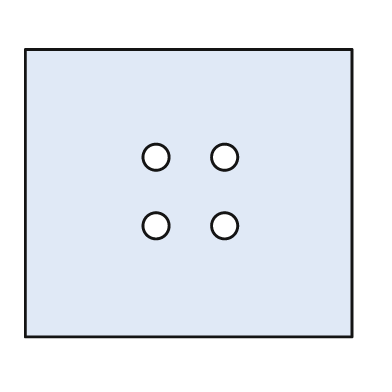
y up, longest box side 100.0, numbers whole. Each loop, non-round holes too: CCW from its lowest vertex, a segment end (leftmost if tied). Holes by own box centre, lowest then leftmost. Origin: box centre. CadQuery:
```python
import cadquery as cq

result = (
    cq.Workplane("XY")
    .moveTo(-50.0, -44.0)
    .lineTo(50.0, -44.0)
    .lineTo(50.0, 44.0)
    .lineTo(-50.0, 44.0)
    .close()
    .moveTo(-10.0, -10.0)
    .circle(4.0)
    .moveTo(11.0, -10.0)
    .circle(4.0)
    .moveTo(-10.0, 11.0)
    .circle(4.0)
    .moveTo(11.0, 11.0)
    .circle(4.0)
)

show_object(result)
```